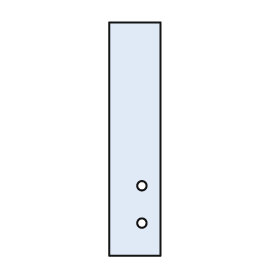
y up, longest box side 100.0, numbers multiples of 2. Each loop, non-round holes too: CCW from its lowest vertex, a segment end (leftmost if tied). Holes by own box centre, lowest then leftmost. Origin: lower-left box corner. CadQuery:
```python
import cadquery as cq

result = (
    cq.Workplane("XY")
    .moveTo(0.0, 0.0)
    .lineTo(22.0, 0.0)
    .lineTo(22.0, 100.0)
    .lineTo(0.0, 100.0)
    .close()
    .moveTo(14.0, 14.0)
    .circle(2.0)
    .moveTo(14.0, 30.0)
    .circle(2.0)
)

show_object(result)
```